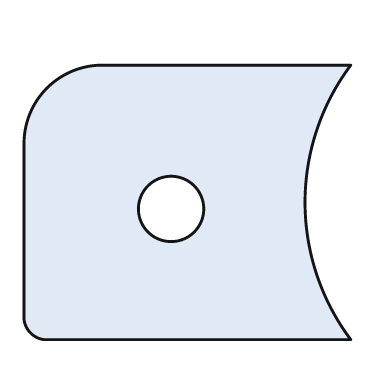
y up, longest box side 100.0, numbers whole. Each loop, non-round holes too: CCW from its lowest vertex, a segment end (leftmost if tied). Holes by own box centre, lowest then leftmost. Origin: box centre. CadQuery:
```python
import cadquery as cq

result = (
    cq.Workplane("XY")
    .moveTo(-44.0, -42.0)
    .lineTo(50.0, -42.0)
    .threePointArc((36.0, 0.0), (50.0, 42.0))
    .lineTo(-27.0, 42.0)
    .threePointArc((-43.0, 35.0), (-50.0, 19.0))
    .lineTo(-50.0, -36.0)
    .threePointArc((-48.0, -40.0), (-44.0, -42.0))
    .close()
    .moveTo(-5.0, -2.0)
    .circle(10.0)
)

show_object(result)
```